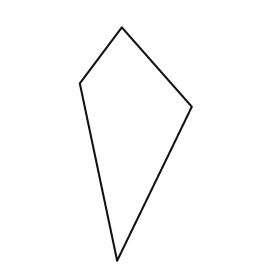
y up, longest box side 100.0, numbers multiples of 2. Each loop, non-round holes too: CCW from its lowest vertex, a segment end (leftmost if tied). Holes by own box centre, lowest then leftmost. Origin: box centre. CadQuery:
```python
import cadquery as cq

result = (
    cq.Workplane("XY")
    .moveTo(-8.0, -50.0)
    .lineTo(24.0, 16.0)
    .lineTo(-6.0, 50.0)
    .lineTo(-24.0, 26.0)
    .close()
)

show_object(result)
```